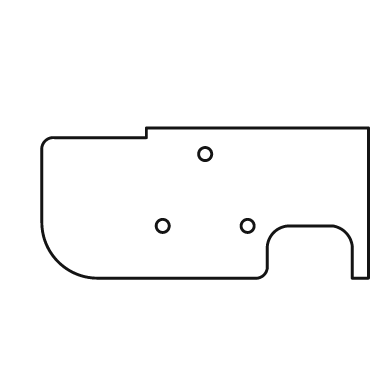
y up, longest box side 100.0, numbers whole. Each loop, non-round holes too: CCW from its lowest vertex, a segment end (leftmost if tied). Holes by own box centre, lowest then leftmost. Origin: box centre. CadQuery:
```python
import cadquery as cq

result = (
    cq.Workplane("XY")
    .moveTo(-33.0, -23.0)
    .lineTo(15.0, -23.0)
    .threePointArc((18.0, -22.0), (19.0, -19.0))
    .lineTo(19.0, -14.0)
    .threePointArc((21.0, -9.0), (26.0, -7.0))
    .lineTo(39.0, -7.0)
    .threePointArc((43.0, -9.0), (45.0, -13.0))
    .lineTo(45.0, -23.0)
    .lineTo(50.0, -23.0)
    .lineTo(50.0, 23.0)
    .lineTo(-18.0, 23.0)
    .lineTo(-18.0, 20.0)
    .lineTo(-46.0, 20.0)
    .threePointArc((-49.0, 19.0), (-50.0, 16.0))
    .lineTo(-50.0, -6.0)
    .threePointArc((-45.0, -18.0), (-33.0, -23.0))
    .close()
    .moveTo(-13.0, -7.0)
    .circle(2.0)
    .moveTo(13.0, -7.0)
    .circle(2.0)
    .moveTo(0.0, 15.0)
    .circle(2.0)
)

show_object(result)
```